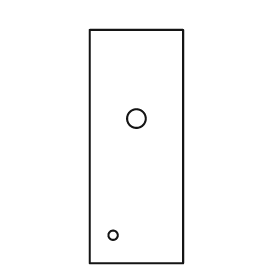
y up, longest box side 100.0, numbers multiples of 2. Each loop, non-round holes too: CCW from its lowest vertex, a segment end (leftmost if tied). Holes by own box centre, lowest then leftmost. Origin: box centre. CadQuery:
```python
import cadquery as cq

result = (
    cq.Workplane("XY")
    .moveTo(-20.0, -50.0)
    .lineTo(20.0, -50.0)
    .lineTo(20.0, 50.0)
    .lineTo(-20.0, 50.0)
    .close()
    .moveTo(-10.0, -38.0)
    .circle(2.0)
    .moveTo(0.0, 12.0)
    .circle(4.0)
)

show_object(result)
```